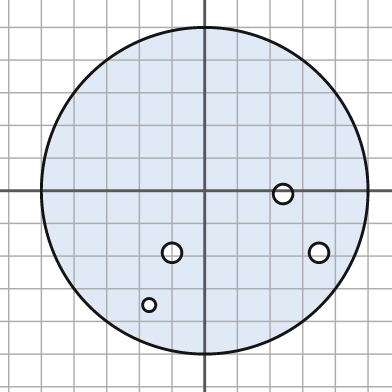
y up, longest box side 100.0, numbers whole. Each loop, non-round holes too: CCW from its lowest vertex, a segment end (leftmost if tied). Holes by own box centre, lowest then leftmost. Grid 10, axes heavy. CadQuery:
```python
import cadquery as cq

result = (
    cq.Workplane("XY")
    .moveTo(0.0, 0.0)
    .circle(50.0)
    .moveTo(-17.0, -35.0)
    .circle(2.0)
    .moveTo(-10.0, -19.0)
    .circle(3.0)
    .moveTo(35.0, -19.0)
    .circle(3.0)
    .moveTo(24.0, -1.0)
    .circle(3.0)
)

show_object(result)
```